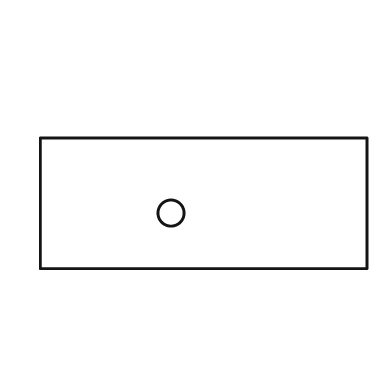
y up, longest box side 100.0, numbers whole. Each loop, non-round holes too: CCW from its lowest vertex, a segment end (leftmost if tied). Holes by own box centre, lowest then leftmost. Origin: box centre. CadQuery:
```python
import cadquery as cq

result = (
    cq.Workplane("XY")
    .moveTo(-50.0, -20.0)
    .lineTo(50.0, -20.0)
    .lineTo(50.0, 20.0)
    .lineTo(-50.0, 20.0)
    .close()
    .moveTo(-10.0, -3.0)
    .circle(4.0)
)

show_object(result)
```